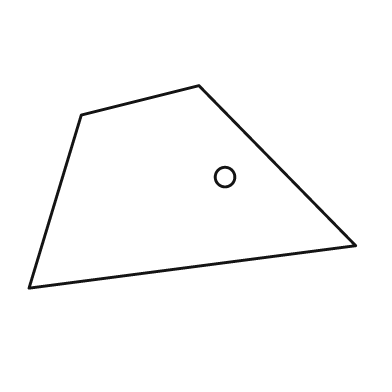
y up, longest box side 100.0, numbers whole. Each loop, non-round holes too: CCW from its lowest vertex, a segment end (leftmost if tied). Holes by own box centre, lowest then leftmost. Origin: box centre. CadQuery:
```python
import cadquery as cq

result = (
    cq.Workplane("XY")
    .moveTo(-50.0, -31.0)
    .lineTo(50.0, -18.0)
    .lineTo(2.0, 31.0)
    .lineTo(-34.0, 22.0)
    .close()
    .moveTo(10.0, 3.0)
    .circle(3.0)
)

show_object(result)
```